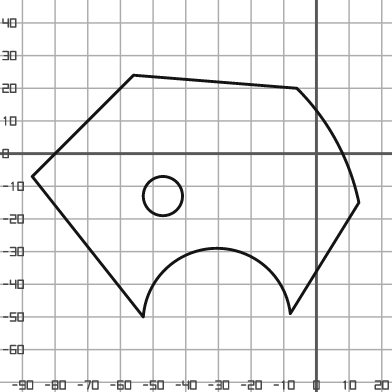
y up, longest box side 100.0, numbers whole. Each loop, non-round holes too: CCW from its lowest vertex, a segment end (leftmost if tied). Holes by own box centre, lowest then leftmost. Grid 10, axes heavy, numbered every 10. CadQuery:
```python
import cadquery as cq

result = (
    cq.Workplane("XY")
    .moveTo(-53.0, -50.0)
    .threePointArc((-31.0, -29.0), (-8.0, -49.0))
    .lineTo(13.0, -15.0)
    .threePointArc((6.0, 4.0), (-6.0, 20.0))
    .lineTo(-56.0, 24.0)
    .lineTo(-87.0, -7.0)
    .close()
    .moveTo(-47.0, -13.0)
    .circle(6.0)
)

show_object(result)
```